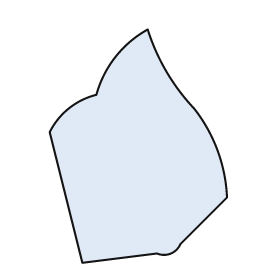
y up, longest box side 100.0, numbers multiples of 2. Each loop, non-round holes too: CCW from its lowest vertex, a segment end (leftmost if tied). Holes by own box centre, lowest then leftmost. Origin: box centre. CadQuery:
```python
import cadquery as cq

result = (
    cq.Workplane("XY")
    .moveTo(-24.0, -50.0)
    .lineTo(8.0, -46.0)
    .threePointArc((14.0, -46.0), (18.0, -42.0))
    .lineTo(38.0, -22.0)
    .threePointArc((34.0, -2.0), (24.0, 16.0))
    .threePointArc((12.0, 32.0), (4.0, 50.0))
    .threePointArc((-10.0, 38.0), (-18.0, 22.0))
    .threePointArc((-30.0, 16.0), (-38.0, 6.0))
    .close()
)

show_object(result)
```